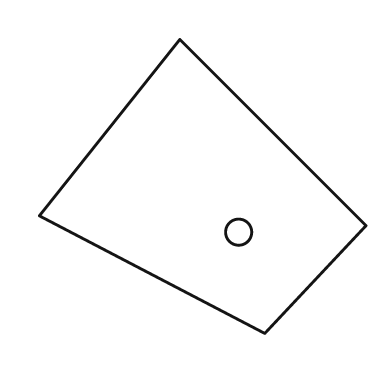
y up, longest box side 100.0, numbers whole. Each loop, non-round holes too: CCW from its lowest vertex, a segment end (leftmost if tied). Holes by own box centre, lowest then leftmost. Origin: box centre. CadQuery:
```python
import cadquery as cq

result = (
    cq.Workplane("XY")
    .moveTo(19.0, -45.0)
    .lineTo(50.0, -12.0)
    .lineTo(-7.0, 45.0)
    .lineTo(-50.0, -9.0)
    .close()
    .moveTo(11.0, -14.0)
    .circle(4.0)
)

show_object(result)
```